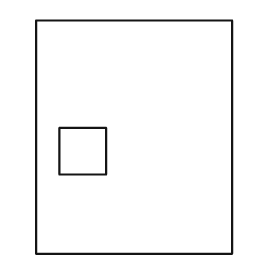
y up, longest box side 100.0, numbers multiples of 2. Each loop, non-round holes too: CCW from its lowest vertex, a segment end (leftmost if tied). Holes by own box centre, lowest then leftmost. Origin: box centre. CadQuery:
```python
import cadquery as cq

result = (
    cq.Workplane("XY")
    .moveTo(-42.0, -50.0)
    .lineTo(42.0, -50.0)
    .lineTo(42.0, 50.0)
    .lineTo(-42.0, 50.0)
    .close()
    .moveTo(-32.0, -16.0)
    .lineTo(-12.0, -16.0)
    .lineTo(-12.0, 4.0)
    .lineTo(-32.0, 4.0)
    .close()
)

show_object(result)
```